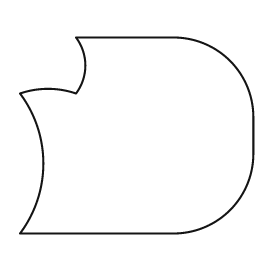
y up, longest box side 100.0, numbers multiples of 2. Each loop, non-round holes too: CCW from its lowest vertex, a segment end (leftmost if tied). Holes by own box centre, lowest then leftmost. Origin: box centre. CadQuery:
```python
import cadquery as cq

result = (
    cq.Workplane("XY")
    .moveTo(-50.0, -42.0)
    .lineTo(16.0, -42.0)
    .threePointArc((40.0, -32.0), (50.0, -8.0))
    .lineTo(50.0, 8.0)
    .threePointArc((40.0, 32.0), (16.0, 42.0))
    .lineTo(-26.0, 42.0)
    .threePointArc((-22.0, 30.0), (-26.0, 18.0))
    .threePointArc((-38.0, 20.0), (-50.0, 18.0))
    .threePointArc((-40.0, -12.0), (-50.0, -42.0))
    .close()
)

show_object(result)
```